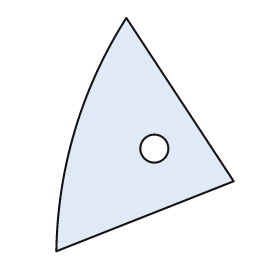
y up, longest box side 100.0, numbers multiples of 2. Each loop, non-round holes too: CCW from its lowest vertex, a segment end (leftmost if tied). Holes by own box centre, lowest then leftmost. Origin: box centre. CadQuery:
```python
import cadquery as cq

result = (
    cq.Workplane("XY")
    .moveTo(-38.0, -50.0)
    .lineTo(38.0, -20.0)
    .lineTo(-8.0, 50.0)
    .threePointArc((-30.0, 2.0), (-38.0, -50.0))
    .close()
    .moveTo(4.0, -6.0)
    .circle(6.0)
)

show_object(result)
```